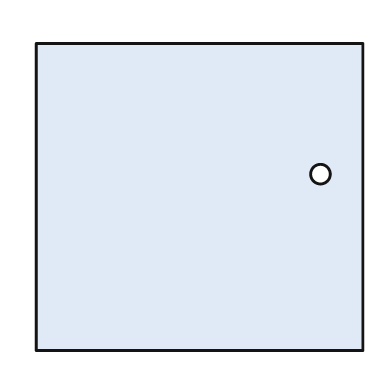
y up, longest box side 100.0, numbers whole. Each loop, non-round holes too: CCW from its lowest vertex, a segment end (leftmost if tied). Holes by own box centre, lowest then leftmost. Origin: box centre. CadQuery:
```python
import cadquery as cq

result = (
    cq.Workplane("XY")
    .moveTo(-50.0, -47.0)
    .lineTo(50.0, -47.0)
    .lineTo(50.0, 47.0)
    .lineTo(-50.0, 47.0)
    .close()
    .moveTo(37.0, 7.0)
    .circle(3.0)
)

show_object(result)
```